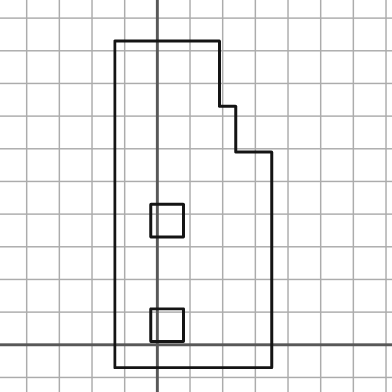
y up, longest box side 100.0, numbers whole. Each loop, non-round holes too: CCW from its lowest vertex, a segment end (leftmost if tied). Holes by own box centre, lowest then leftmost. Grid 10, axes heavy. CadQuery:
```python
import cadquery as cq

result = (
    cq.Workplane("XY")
    .moveTo(-13.0, -7.0)
    .lineTo(35.0, -7.0)
    .lineTo(35.0, 59.0)
    .lineTo(24.0, 59.0)
    .lineTo(24.0, 73.0)
    .lineTo(19.0, 73.0)
    .lineTo(19.0, 93.0)
    .lineTo(-13.0, 93.0)
    .close()
    .moveTo(-2.0, 1.0)
    .lineTo(8.0, 1.0)
    .lineTo(8.0, 11.0)
    .lineTo(-2.0, 11.0)
    .close()
    .moveTo(-2.0, 33.0)
    .lineTo(8.0, 33.0)
    .lineTo(8.0, 43.0)
    .lineTo(-2.0, 43.0)
    .close()
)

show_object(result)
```